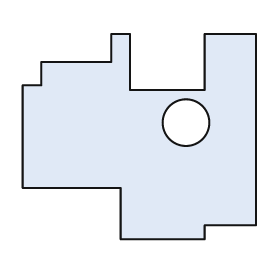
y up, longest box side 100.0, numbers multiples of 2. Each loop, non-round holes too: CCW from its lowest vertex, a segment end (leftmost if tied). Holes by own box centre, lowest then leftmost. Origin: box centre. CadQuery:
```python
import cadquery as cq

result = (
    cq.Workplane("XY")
    .moveTo(-8.0, -44.0)
    .lineTo(28.0, -44.0)
    .lineTo(28.0, -38.0)
    .lineTo(50.0, -38.0)
    .lineTo(50.0, 44.0)
    .lineTo(28.0, 44.0)
    .lineTo(28.0, 20.0)
    .lineTo(-4.0, 20.0)
    .lineTo(-4.0, 44.0)
    .lineTo(-12.0, 44.0)
    .lineTo(-12.0, 32.0)
    .lineTo(-42.0, 32.0)
    .lineTo(-42.0, 22.0)
    .lineTo(-50.0, 22.0)
    .lineTo(-50.0, -22.0)
    .lineTo(-8.0, -22.0)
    .close()
    .moveTo(20.0, 6.0)
    .circle(10.0)
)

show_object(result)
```